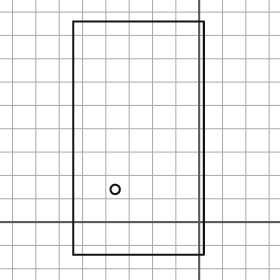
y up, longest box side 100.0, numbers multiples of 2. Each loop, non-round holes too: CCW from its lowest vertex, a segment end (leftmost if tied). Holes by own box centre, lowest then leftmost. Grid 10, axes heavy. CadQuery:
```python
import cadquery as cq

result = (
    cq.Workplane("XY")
    .moveTo(-54.0, -14.0)
    .lineTo(2.0, -14.0)
    .lineTo(2.0, 86.0)
    .lineTo(-54.0, 86.0)
    .close()
    .moveTo(-36.0, 14.0)
    .circle(2.0)
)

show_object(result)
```